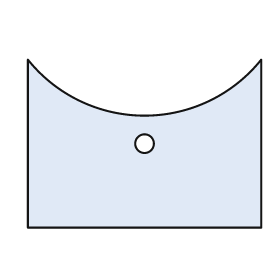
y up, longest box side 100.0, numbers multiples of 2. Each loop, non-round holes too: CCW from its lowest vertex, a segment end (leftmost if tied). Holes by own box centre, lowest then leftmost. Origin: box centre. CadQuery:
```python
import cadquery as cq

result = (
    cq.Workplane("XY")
    .moveTo(-50.0, -36.0)
    .lineTo(50.0, -36.0)
    .lineTo(50.0, 36.0)
    .threePointArc((0.0, 12.0), (-50.0, 36.0))
    .close()
    .moveTo(0.0, 0.0)
    .circle(4.0)
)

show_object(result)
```